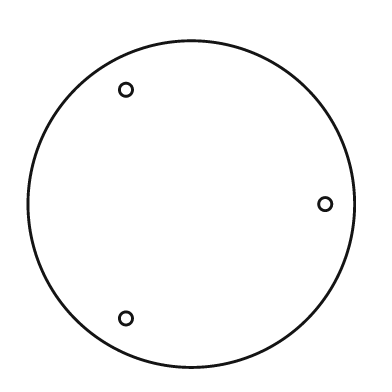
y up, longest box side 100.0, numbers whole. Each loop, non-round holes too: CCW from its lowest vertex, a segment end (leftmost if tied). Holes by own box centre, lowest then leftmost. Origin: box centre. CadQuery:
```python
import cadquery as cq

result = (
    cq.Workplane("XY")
    .moveTo(0.0, 0.0)
    .circle(50.0)
    .moveTo(-20.0, -35.0)
    .circle(2.0)
    .moveTo(41.0, 0.0)
    .circle(2.0)
    .moveTo(-20.0, 35.0)
    .circle(2.0)
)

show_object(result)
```